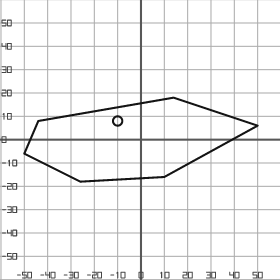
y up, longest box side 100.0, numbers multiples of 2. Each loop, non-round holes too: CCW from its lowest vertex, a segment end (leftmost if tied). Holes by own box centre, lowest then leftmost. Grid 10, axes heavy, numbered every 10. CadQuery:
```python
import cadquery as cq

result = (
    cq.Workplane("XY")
    .moveTo(-26.0, -18.0)
    .lineTo(10.0, -16.0)
    .lineTo(50.0, 6.0)
    .lineTo(14.0, 18.0)
    .lineTo(-44.0, 8.0)
    .lineTo(-50.0, -6.0)
    .close()
    .moveTo(-10.0, 8.0)
    .circle(2.0)
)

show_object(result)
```